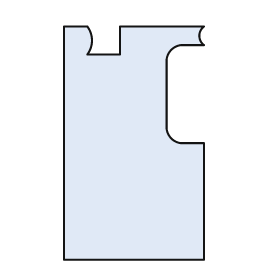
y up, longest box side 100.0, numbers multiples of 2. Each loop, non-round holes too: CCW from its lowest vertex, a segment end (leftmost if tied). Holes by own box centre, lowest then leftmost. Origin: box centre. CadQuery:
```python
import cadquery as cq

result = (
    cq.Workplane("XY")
    .moveTo(-30.0, -50.0)
    .lineTo(30.0, -50.0)
    .lineTo(30.0, 0.0)
    .lineTo(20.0, 0.0)
    .threePointArc((16.0, 2.0), (14.0, 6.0))
    .lineTo(14.0, 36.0)
    .threePointArc((16.0, 40.0), (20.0, 42.0))
    .lineTo(30.0, 42.0)
    .threePointArc((28.0, 46.0), (30.0, 50.0))
    .lineTo(-6.0, 50.0)
    .lineTo(-6.0, 38.0)
    .lineTo(-20.0, 38.0)
    .threePointArc((-18.0, 44.0), (-20.0, 50.0))
    .lineTo(-30.0, 50.0)
    .close()
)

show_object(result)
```